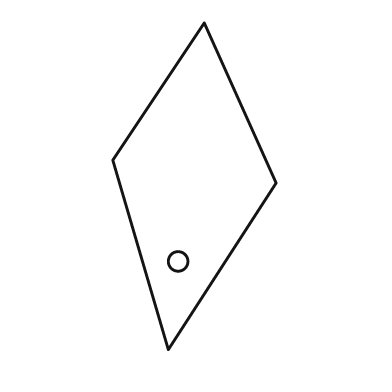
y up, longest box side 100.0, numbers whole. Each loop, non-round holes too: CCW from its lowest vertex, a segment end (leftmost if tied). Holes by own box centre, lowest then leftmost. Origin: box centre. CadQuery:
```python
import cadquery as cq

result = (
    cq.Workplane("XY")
    .moveTo(-8.0, -50.0)
    .lineTo(25.0, 1.0)
    .lineTo(3.0, 50.0)
    .lineTo(-25.0, 8.0)
    .close()
    .moveTo(-5.0, -23.0)
    .circle(3.0)
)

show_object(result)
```